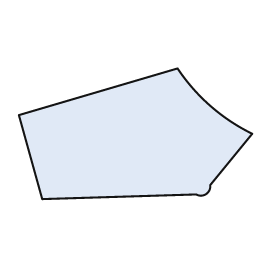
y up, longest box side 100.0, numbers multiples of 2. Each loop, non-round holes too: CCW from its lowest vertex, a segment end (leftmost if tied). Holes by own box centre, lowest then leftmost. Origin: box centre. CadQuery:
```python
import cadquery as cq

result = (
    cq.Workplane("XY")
    .moveTo(-40.0, -28.0)
    .lineTo(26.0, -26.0)
    .threePointArc((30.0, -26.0), (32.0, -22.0))
    .lineTo(50.0, 0.0)
    .threePointArc((32.0, 12.0), (18.0, 28.0))
    .lineTo(-50.0, 8.0)
    .close()
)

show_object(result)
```